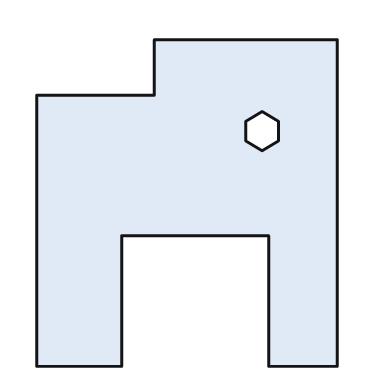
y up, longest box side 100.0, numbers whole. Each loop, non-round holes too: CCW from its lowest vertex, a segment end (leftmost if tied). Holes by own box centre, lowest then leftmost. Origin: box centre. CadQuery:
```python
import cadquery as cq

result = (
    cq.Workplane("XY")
    .moveTo(-46.0, -50.0)
    .lineTo(-20.0, -50.0)
    .lineTo(-20.0, -10.0)
    .lineTo(25.0, -10.0)
    .lineTo(25.0, -50.0)
    .lineTo(46.0, -50.0)
    .lineTo(46.0, 50.0)
    .lineTo(-10.0, 50.0)
    .lineTo(-10.0, 33.0)
    .lineTo(-46.0, 33.0)
    .close()
    .moveTo(23.0, 16.0)
    .lineTo(28.0, 19.0)
    .lineTo(28.0, 25.0)
    .lineTo(23.0, 28.0)
    .lineTo(18.0, 25.0)
    .lineTo(18.0, 19.0)
    .close()
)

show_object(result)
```